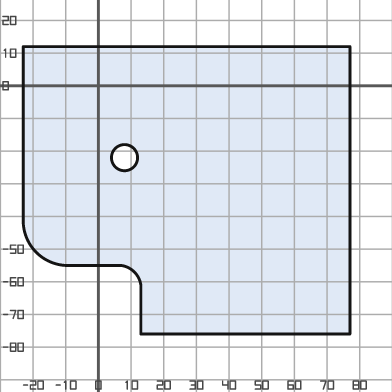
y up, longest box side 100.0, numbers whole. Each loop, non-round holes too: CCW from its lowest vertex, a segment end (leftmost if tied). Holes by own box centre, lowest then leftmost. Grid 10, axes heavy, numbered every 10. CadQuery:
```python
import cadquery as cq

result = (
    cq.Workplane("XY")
    .moveTo(13.0, -76.0)
    .lineTo(77.0, -76.0)
    .lineTo(77.0, 12.0)
    .lineTo(-23.0, 12.0)
    .lineTo(-23.0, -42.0)
    .threePointArc((-19.0, -51.0), (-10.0, -55.0))
    .lineTo(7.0, -55.0)
    .threePointArc((11.0, -57.0), (13.0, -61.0))
    .close()
    .moveTo(8.0, -22.0)
    .circle(4.0)
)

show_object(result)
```